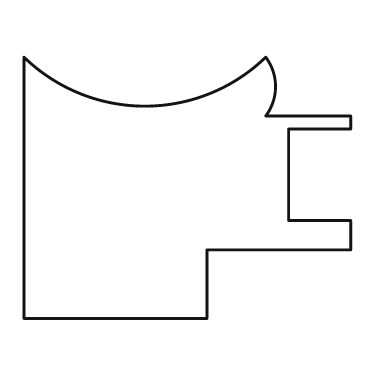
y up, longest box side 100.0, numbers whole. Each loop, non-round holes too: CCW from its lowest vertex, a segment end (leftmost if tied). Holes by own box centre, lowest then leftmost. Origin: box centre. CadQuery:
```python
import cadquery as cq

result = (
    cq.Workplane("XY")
    .moveTo(-50.0, -40.0)
    .lineTo(6.0, -40.0)
    .lineTo(6.0, -19.0)
    .lineTo(50.0, -19.0)
    .lineTo(50.0, -10.0)
    .lineTo(31.0, -10.0)
    .lineTo(31.0, 18.0)
    .lineTo(50.0, 18.0)
    .lineTo(50.0, 22.0)
    .lineTo(24.0, 22.0)
    .threePointArc((27.0, 31.0), (24.0, 40.0))
    .threePointArc((-13.0, 25.0), (-50.0, 40.0))
    .close()
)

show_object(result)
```